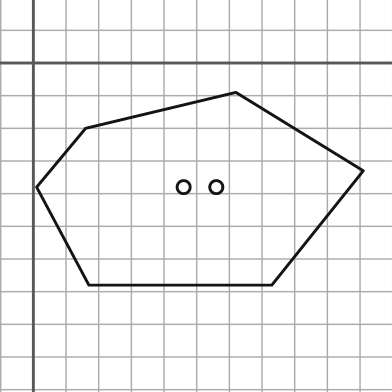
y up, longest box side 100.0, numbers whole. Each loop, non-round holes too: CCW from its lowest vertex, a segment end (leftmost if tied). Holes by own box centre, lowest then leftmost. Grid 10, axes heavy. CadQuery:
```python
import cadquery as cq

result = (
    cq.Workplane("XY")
    .moveTo(17.0, -68.0)
    .lineTo(73.0, -68.0)
    .lineTo(101.0, -33.0)
    .lineTo(62.0, -9.0)
    .lineTo(16.0, -20.0)
    .lineTo(1.0, -38.0)
    .close()
    .moveTo(46.0, -38.0)
    .circle(2.0)
    .moveTo(56.0, -38.0)
    .circle(2.0)
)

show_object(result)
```